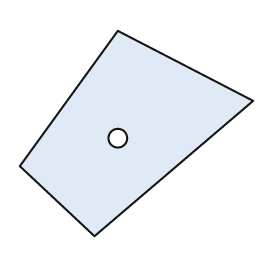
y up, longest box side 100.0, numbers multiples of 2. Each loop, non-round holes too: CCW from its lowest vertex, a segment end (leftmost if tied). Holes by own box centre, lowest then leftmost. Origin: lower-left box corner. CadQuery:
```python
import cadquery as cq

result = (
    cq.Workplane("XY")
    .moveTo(32.0, 0.0)
    .lineTo(100.0, 58.0)
    .lineTo(42.0, 88.0)
    .lineTo(0.0, 30.0)
    .close()
    .moveTo(42.0, 42.0)
    .circle(4.0)
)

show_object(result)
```